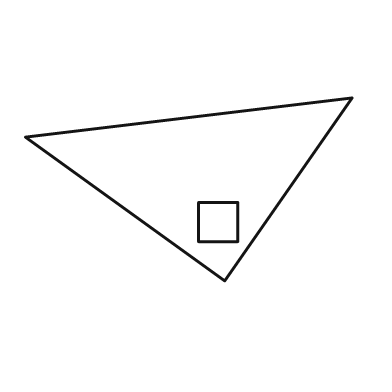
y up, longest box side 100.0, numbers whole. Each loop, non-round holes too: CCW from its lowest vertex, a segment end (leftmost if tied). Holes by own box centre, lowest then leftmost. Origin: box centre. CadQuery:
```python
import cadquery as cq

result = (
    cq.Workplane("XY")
    .moveTo(11.0, -28.0)
    .lineTo(50.0, 28.0)
    .lineTo(-50.0, 16.0)
    .close()
    .moveTo(3.0, -16.0)
    .lineTo(15.0, -16.0)
    .lineTo(15.0, -4.0)
    .lineTo(3.0, -4.0)
    .close()
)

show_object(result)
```